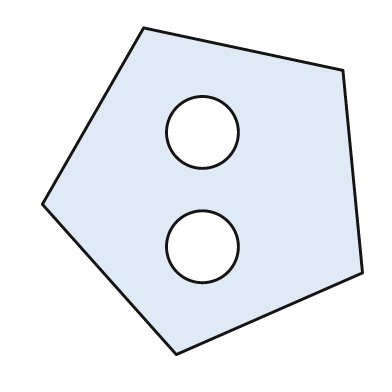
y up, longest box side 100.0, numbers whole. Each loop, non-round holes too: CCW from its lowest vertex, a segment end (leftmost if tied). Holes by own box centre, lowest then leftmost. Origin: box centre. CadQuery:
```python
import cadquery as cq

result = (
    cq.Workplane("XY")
    .moveTo(-8.0, -50.0)
    .lineTo(49.0, -25.0)
    .lineTo(43.0, 37.0)
    .lineTo(-18.0, 50.0)
    .lineTo(-49.0, -4.0)
    .close()
    .moveTo(0.0, -17.0)
    .circle(11.0)
    .moveTo(0.0, 18.0)
    .circle(11.0)
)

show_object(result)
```